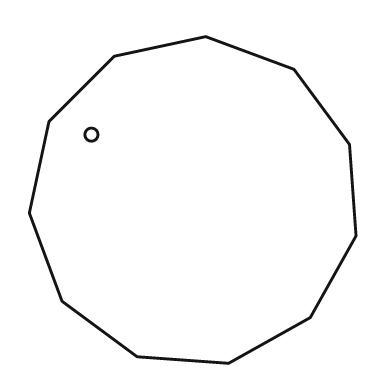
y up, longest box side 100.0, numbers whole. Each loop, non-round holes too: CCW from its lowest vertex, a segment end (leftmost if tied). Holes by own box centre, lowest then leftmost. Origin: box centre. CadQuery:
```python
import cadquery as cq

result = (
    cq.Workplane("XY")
    .moveTo(11.0, -50.0)
    .lineTo(36.0, -36.0)
    .lineTo(50.0, -11.0)
    .lineTo(48.0, 17.0)
    .lineTo(31.0, 40.0)
    .lineTo(4.0, 50.0)
    .lineTo(-24.0, 44.0)
    .lineTo(-44.0, 24.0)
    .lineTo(-50.0, -4.0)
    .lineTo(-40.0, -31.0)
    .lineTo(-17.0, -48.0)
    .close()
    .moveTo(-31.0, 20.0)
    .circle(2.0)
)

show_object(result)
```